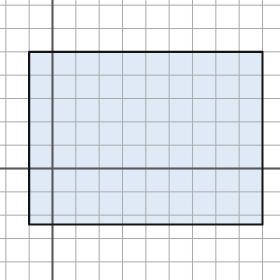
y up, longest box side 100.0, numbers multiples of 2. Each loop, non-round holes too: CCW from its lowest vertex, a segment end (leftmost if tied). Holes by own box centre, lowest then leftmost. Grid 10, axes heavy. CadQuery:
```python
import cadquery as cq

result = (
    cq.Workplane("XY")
    .moveTo(-10.0, -24.0)
    .lineTo(90.0, -24.0)
    .lineTo(90.0, 50.0)
    .lineTo(-10.0, 50.0)
    .close()
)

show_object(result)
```